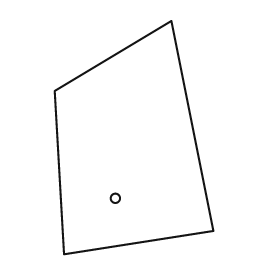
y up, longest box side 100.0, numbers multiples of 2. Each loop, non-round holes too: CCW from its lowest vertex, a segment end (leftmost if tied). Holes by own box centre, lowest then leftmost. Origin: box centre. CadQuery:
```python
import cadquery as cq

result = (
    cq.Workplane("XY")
    .moveTo(-30.0, -50.0)
    .lineTo(34.0, -40.0)
    .lineTo(16.0, 50.0)
    .lineTo(-34.0, 20.0)
    .close()
    .moveTo(-8.0, -26.0)
    .circle(2.0)
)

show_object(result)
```